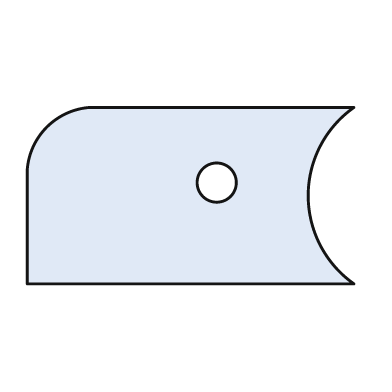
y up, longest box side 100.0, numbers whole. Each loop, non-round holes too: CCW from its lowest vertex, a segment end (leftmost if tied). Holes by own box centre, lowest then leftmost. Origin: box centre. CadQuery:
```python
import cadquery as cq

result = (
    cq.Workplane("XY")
    .moveTo(-50.0, -27.0)
    .lineTo(50.0, -27.0)
    .threePointArc((36.0, 0.0), (50.0, 27.0))
    .lineTo(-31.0, 27.0)
    .threePointArc((-44.0, 21.0), (-50.0, 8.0))
    .close()
    .moveTo(8.0, 4.0)
    .circle(6.0)
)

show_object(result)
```